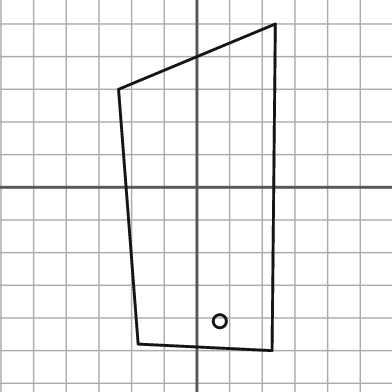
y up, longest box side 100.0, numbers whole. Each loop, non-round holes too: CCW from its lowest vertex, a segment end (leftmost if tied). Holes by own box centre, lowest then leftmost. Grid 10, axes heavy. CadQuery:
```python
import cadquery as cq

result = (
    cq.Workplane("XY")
    .moveTo(23.0, -50.0)
    .lineTo(24.0, 50.0)
    .lineTo(-24.0, 30.0)
    .lineTo(-18.0, -48.0)
    .close()
    .moveTo(7.0, -41.0)
    .circle(2.0)
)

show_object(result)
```